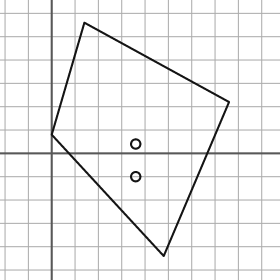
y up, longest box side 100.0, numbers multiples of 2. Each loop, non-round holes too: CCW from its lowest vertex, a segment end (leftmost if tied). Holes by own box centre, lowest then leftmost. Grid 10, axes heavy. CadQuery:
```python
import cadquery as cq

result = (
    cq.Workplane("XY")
    .moveTo(48.0, -44.0)
    .lineTo(76.0, 22.0)
    .lineTo(14.0, 56.0)
    .lineTo(0.0, 8.0)
    .close()
    .moveTo(36.0, -10.0)
    .circle(2.0)
    .moveTo(36.0, 4.0)
    .circle(2.0)
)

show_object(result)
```